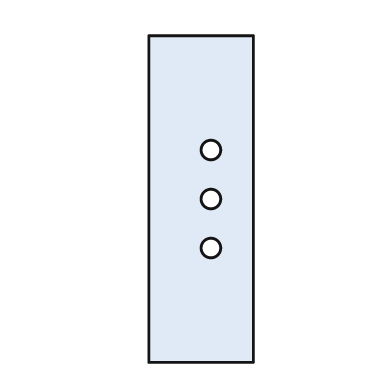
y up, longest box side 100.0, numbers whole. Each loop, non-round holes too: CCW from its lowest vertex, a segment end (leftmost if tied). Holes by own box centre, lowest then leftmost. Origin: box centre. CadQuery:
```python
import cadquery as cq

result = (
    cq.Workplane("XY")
    .moveTo(-16.0, -50.0)
    .lineTo(16.0, -50.0)
    .lineTo(16.0, 50.0)
    .lineTo(-16.0, 50.0)
    .close()
    .moveTo(3.0, -15.0)
    .circle(3.0)
    .moveTo(3.0, 0.0)
    .circle(3.0)
    .moveTo(3.0, 15.0)
    .circle(3.0)
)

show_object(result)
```